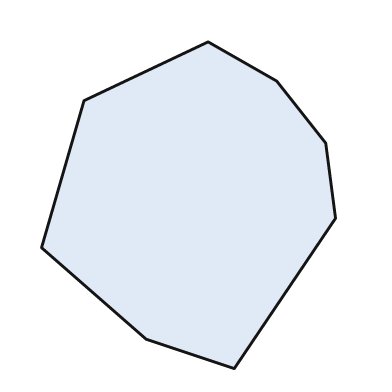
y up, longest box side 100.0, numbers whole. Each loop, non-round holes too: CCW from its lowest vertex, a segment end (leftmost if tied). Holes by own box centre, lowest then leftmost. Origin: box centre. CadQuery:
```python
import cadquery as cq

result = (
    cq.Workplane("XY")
    .moveTo(14.0, -50.0)
    .lineTo(45.0, -4.0)
    .lineTo(42.0, 19.0)
    .lineTo(27.0, 38.0)
    .lineTo(6.0, 50.0)
    .lineTo(-32.0, 32.0)
    .lineTo(-45.0, -13.0)
    .lineTo(-13.0, -41.0)
    .close()
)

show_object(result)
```